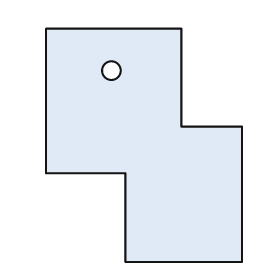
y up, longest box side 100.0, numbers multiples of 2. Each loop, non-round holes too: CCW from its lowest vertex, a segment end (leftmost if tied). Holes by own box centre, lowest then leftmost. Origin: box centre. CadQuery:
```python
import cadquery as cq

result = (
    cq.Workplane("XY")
    .moveTo(-8.0, -50.0)
    .lineTo(42.0, -50.0)
    .lineTo(42.0, 8.0)
    .lineTo(16.0, 8.0)
    .lineTo(16.0, 50.0)
    .lineTo(-42.0, 50.0)
    .lineTo(-42.0, -12.0)
    .lineTo(-8.0, -12.0)
    .close()
    .moveTo(-14.0, 32.0)
    .circle(4.0)
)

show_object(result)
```